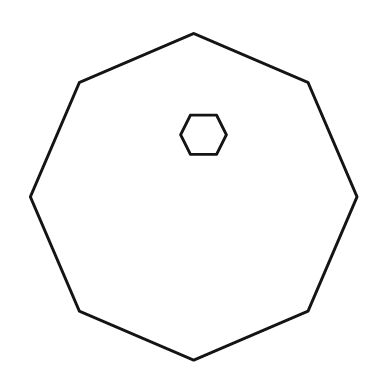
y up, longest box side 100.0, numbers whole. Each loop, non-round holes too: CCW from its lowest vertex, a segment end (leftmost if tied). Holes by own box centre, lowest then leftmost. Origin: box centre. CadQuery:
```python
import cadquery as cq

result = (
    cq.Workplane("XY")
    .moveTo(0.0, -50.0)
    .lineTo(35.0, -35.0)
    .lineTo(50.0, 0.0)
    .lineTo(35.0, 35.0)
    .lineTo(0.0, 50.0)
    .lineTo(-35.0, 35.0)
    .lineTo(-50.0, 0.0)
    .lineTo(-35.0, -35.0)
    .close()
    .moveTo(-1.0, 13.0)
    .lineTo(7.0, 13.0)
    .lineTo(10.0, 19.0)
    .lineTo(7.0, 25.0)
    .lineTo(-1.0, 25.0)
    .lineTo(-4.0, 19.0)
    .close()
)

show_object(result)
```